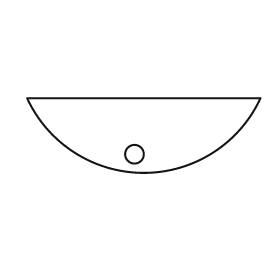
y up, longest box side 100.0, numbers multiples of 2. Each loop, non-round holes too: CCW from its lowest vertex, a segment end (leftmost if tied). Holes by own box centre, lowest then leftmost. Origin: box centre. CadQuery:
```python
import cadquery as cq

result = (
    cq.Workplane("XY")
    .moveTo(-50.0, 16.0)
    .threePointArc((0.0, -16.0), (50.0, 16.0))
    .close()
    .moveTo(-4.0, -8.0)
    .circle(4.0)
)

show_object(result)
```